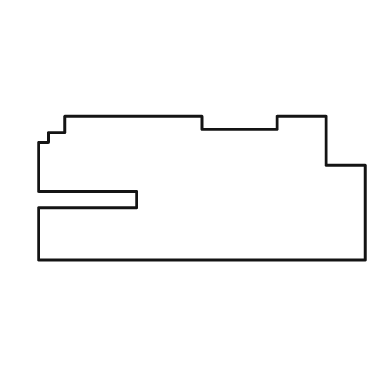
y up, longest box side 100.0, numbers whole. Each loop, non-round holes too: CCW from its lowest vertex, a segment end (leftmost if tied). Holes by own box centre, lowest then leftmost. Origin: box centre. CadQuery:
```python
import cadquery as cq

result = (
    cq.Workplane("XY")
    .moveTo(-50.0, -22.0)
    .lineTo(50.0, -22.0)
    .lineTo(50.0, 7.0)
    .lineTo(38.0, 7.0)
    .lineTo(38.0, 22.0)
    .lineTo(23.0, 22.0)
    .lineTo(23.0, 18.0)
    .lineTo(0.0, 18.0)
    .lineTo(0.0, 22.0)
    .lineTo(-42.0, 22.0)
    .lineTo(-42.0, 17.0)
    .lineTo(-47.0, 17.0)
    .lineTo(-47.0, 14.0)
    .lineTo(-50.0, 14.0)
    .lineTo(-50.0, -1.0)
    .lineTo(-20.0, -1.0)
    .lineTo(-20.0, -6.0)
    .lineTo(-50.0, -6.0)
    .close()
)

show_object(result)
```